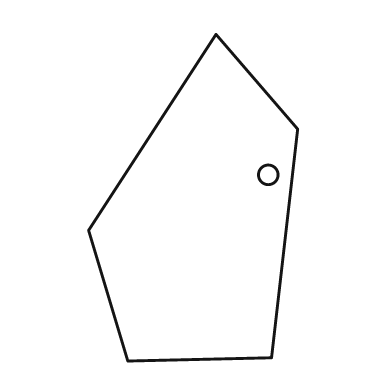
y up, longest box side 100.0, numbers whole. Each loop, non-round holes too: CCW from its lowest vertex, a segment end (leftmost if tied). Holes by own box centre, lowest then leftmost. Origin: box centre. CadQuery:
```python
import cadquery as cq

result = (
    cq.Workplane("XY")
    .moveTo(-20.0, -50.0)
    .lineTo(24.0, -49.0)
    .lineTo(32.0, 21.0)
    .lineTo(7.0, 50.0)
    .lineTo(-32.0, -10.0)
    .close()
    .moveTo(23.0, 7.0)
    .circle(3.0)
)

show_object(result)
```